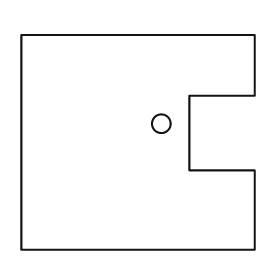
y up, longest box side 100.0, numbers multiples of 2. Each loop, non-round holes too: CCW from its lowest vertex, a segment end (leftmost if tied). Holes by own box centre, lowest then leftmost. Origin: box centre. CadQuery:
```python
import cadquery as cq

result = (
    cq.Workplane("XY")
    .moveTo(-50.0, -46.0)
    .lineTo(50.0, -46.0)
    .lineTo(50.0, -12.0)
    .lineTo(22.0, -12.0)
    .lineTo(22.0, 20.0)
    .lineTo(50.0, 20.0)
    .lineTo(50.0, 46.0)
    .lineTo(-50.0, 46.0)
    .close()
    .moveTo(10.0, 8.0)
    .circle(4.0)
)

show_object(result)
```